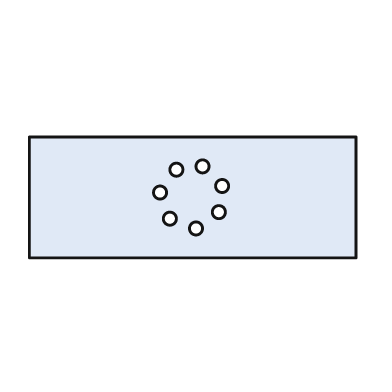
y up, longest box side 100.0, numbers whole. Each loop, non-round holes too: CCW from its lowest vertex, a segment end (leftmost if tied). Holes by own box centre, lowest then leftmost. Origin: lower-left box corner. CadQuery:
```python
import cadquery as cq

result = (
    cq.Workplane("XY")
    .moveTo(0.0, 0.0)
    .lineTo(100.0, 0.0)
    .lineTo(100.0, 37.0)
    .lineTo(0.0, 37.0)
    .close()
    .moveTo(51.0, 9.0)
    .circle(2.0)
    .moveTo(43.0, 12.0)
    .circle(2.0)
    .moveTo(58.0, 14.0)
    .circle(2.0)
    .moveTo(40.0, 20.0)
    .circle(2.0)
    .moveTo(59.0, 22.0)
    .circle(2.0)
    .moveTo(45.0, 27.0)
    .circle(2.0)
    .moveTo(53.0, 28.0)
    .circle(2.0)
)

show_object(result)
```